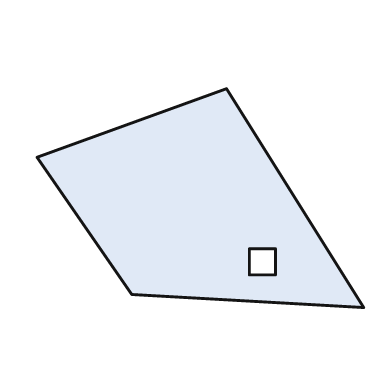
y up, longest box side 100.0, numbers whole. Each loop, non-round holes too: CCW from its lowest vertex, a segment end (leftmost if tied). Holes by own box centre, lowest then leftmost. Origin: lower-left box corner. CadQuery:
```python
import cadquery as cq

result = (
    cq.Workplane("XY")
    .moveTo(100.0, 0.0)
    .lineTo(58.0, 67.0)
    .lineTo(0.0, 46.0)
    .lineTo(29.0, 4.0)
    .close()
    .moveTo(65.0, 10.0)
    .lineTo(73.0, 10.0)
    .lineTo(73.0, 18.0)
    .lineTo(65.0, 18.0)
    .close()
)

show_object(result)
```